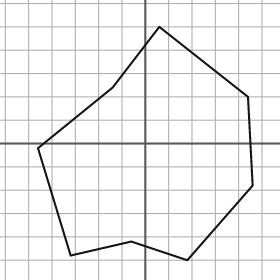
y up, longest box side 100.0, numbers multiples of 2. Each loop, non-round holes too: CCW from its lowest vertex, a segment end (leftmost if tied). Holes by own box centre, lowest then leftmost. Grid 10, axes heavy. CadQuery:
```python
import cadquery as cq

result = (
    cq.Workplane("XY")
    .moveTo(18.0, -50.0)
    .lineTo(46.0, -18.0)
    .lineTo(44.0, 20.0)
    .lineTo(6.0, 50.0)
    .lineTo(-14.0, 24.0)
    .lineTo(-46.0, -2.0)
    .lineTo(-32.0, -48.0)
    .lineTo(-6.0, -42.0)
    .close()
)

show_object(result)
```